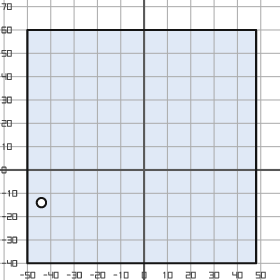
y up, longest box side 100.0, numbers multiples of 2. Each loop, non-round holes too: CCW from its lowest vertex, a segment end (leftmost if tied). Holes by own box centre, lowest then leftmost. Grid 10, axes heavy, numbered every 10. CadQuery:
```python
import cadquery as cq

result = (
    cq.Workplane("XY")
    .moveTo(-50.0, -40.0)
    .lineTo(48.0, -40.0)
    .lineTo(48.0, 60.0)
    .lineTo(-50.0, 60.0)
    .close()
    .moveTo(-44.0, -14.0)
    .circle(2.0)
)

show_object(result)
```